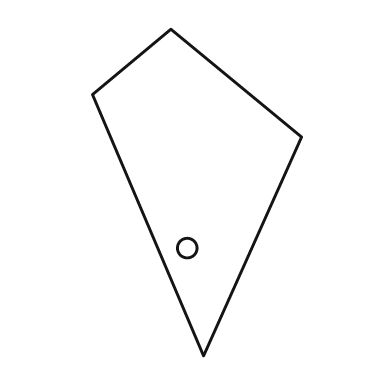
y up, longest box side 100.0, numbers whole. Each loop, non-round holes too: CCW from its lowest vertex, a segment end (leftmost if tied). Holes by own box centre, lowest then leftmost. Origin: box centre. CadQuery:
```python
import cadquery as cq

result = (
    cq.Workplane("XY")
    .moveTo(2.0, -50.0)
    .lineTo(32.0, 17.0)
    .lineTo(-8.0, 50.0)
    .lineTo(-32.0, 30.0)
    .close()
    .moveTo(-3.0, -17.0)
    .circle(3.0)
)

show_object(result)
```